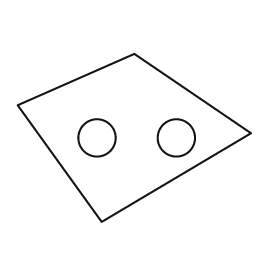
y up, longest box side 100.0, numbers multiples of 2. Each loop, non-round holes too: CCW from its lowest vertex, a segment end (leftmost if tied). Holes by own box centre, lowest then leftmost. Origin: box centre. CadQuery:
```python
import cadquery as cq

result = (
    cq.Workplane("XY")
    .moveTo(-14.0, -36.0)
    .lineTo(50.0, 2.0)
    .lineTo(0.0, 36.0)
    .lineTo(-50.0, 14.0)
    .close()
    .moveTo(-16.0, 0.0)
    .circle(8.0)
    .moveTo(18.0, 0.0)
    .circle(8.0)
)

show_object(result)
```